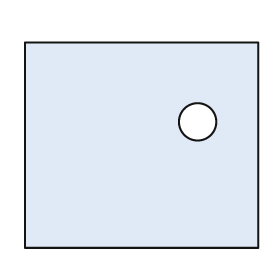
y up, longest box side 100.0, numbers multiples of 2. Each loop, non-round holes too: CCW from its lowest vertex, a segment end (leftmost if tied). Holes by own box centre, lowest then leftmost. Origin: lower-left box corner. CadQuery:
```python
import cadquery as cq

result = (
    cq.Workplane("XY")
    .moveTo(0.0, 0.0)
    .lineTo(100.0, 0.0)
    .lineTo(100.0, 88.0)
    .lineTo(0.0, 88.0)
    .close()
    .moveTo(74.0, 54.0)
    .circle(8.0)
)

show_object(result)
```